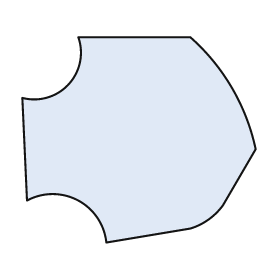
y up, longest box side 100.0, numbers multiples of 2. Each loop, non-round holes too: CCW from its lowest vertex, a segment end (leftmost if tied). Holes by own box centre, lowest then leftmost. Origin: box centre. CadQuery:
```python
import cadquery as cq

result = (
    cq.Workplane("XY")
    .moveTo(-14.0, -44.0)
    .lineTo(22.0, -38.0)
    .threePointArc((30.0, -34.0), (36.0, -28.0))
    .lineTo(50.0, -4.0)
    .threePointArc((40.0, 22.0), (22.0, 44.0))
    .lineTo(-26.0, 44.0)
    .threePointArc((-30.0, 24.0), (-50.0, 18.0))
    .lineTo(-48.0, -26.0)
    .threePointArc((-26.0, -26.0), (-14.0, -44.0))
    .close()
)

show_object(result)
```